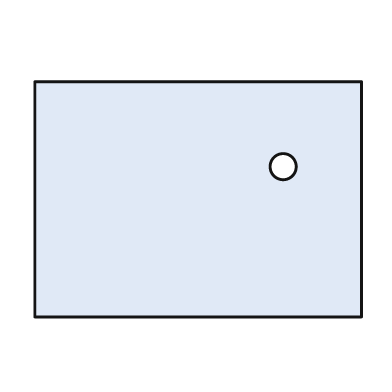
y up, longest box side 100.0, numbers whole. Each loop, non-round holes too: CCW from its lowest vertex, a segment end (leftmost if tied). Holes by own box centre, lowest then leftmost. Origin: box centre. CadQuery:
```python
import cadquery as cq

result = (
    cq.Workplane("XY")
    .moveTo(-50.0, -36.0)
    .lineTo(50.0, -36.0)
    .lineTo(50.0, 36.0)
    .lineTo(-50.0, 36.0)
    .close()
    .moveTo(26.0, 10.0)
    .circle(4.0)
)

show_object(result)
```